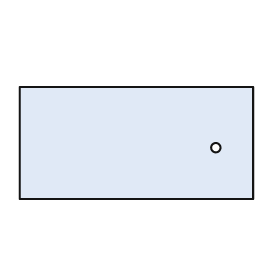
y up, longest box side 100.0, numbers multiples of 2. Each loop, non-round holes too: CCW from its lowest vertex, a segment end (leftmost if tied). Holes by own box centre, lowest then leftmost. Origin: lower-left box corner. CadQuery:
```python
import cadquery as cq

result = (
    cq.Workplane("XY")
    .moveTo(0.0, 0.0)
    .lineTo(100.0, 0.0)
    .lineTo(100.0, 48.0)
    .lineTo(0.0, 48.0)
    .close()
    .moveTo(84.0, 22.0)
    .circle(2.0)
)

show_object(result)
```